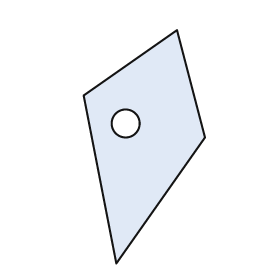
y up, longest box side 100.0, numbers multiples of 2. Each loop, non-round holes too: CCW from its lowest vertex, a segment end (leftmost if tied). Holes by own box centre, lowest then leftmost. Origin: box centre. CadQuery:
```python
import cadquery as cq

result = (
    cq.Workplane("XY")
    .moveTo(-12.0, -50.0)
    .lineTo(26.0, 4.0)
    .lineTo(14.0, 50.0)
    .lineTo(-26.0, 22.0)
    .close()
    .moveTo(-8.0, 10.0)
    .circle(6.0)
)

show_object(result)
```